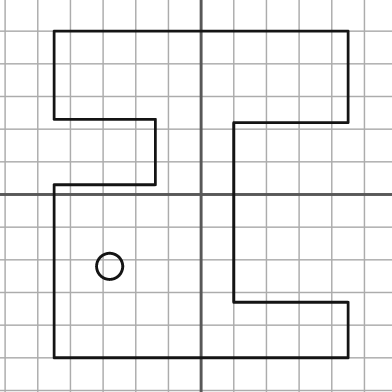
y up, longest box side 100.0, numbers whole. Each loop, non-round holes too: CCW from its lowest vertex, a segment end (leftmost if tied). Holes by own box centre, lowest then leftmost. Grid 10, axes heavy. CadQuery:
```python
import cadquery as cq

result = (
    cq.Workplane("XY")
    .moveTo(-45.0, -50.0)
    .lineTo(45.0, -50.0)
    .lineTo(45.0, -33.0)
    .lineTo(10.0, -33.0)
    .lineTo(10.0, 22.0)
    .lineTo(45.0, 22.0)
    .lineTo(45.0, 50.0)
    .lineTo(-45.0, 50.0)
    .lineTo(-45.0, 23.0)
    .lineTo(-14.0, 23.0)
    .lineTo(-14.0, 3.0)
    .lineTo(-45.0, 3.0)
    .close()
    .moveTo(-28.0, -22.0)
    .circle(4.0)
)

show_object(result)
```